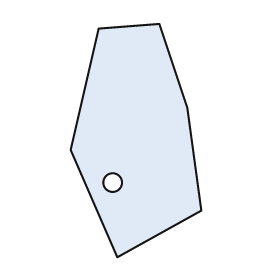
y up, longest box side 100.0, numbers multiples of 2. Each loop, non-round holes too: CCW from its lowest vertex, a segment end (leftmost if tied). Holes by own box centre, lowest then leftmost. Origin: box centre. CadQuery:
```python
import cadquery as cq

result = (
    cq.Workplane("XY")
    .moveTo(-8.0, -50.0)
    .lineTo(28.0, -30.0)
    .lineTo(22.0, 14.0)
    .lineTo(10.0, 50.0)
    .lineTo(-16.0, 48.0)
    .lineTo(-28.0, -4.0)
    .close()
    .moveTo(-10.0, -18.0)
    .circle(4.0)
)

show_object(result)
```